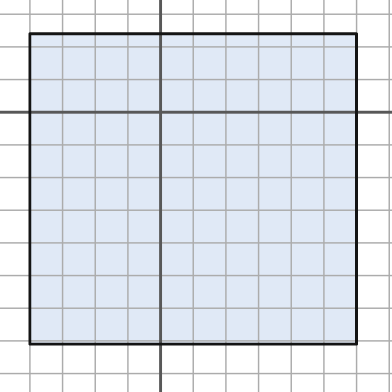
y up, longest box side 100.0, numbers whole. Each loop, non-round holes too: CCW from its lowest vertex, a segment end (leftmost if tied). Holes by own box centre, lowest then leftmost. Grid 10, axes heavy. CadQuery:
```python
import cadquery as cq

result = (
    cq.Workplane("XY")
    .moveTo(-40.0, -71.0)
    .lineTo(60.0, -71.0)
    .lineTo(60.0, 24.0)
    .lineTo(-40.0, 24.0)
    .close()
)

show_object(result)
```